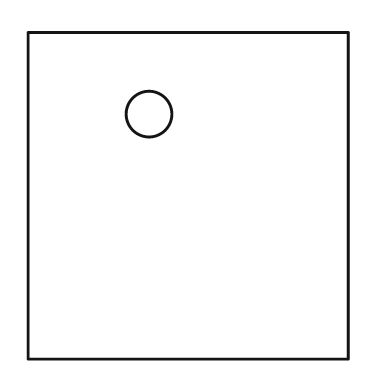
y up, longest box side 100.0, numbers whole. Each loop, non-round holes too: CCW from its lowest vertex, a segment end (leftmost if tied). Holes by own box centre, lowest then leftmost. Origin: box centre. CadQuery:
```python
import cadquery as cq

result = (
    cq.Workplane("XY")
    .moveTo(-49.0, -50.0)
    .lineTo(49.0, -50.0)
    .lineTo(49.0, 50.0)
    .lineTo(-49.0, 50.0)
    .close()
    .moveTo(-12.0, 25.0)
    .circle(7.0)
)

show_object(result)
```